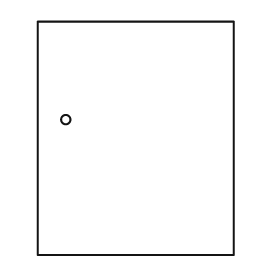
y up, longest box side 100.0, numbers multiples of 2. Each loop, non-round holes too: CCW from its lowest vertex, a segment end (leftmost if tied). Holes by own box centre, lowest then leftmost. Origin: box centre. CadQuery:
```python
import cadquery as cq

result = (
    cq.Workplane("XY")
    .moveTo(-42.0, -50.0)
    .lineTo(42.0, -50.0)
    .lineTo(42.0, 50.0)
    .lineTo(-42.0, 50.0)
    .close()
    .moveTo(-30.0, 8.0)
    .circle(2.0)
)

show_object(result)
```